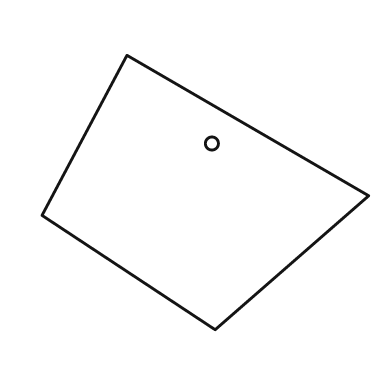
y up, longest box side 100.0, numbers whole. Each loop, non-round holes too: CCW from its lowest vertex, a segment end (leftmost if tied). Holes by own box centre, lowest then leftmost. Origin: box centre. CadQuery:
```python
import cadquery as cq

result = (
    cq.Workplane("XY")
    .moveTo(3.0, -42.0)
    .lineTo(50.0, -1.0)
    .lineTo(-24.0, 42.0)
    .lineTo(-50.0, -7.0)
    .close()
    .moveTo(2.0, 15.0)
    .circle(2.0)
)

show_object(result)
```